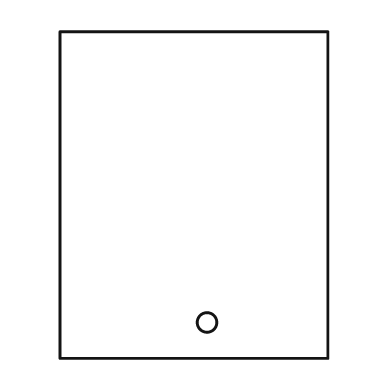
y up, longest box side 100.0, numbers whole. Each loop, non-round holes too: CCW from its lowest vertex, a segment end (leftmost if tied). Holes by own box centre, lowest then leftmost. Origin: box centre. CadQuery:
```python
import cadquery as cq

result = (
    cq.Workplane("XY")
    .moveTo(-41.0, -50.0)
    .lineTo(41.0, -50.0)
    .lineTo(41.0, 50.0)
    .lineTo(-41.0, 50.0)
    .close()
    .moveTo(4.0, -39.0)
    .circle(3.0)
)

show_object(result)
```